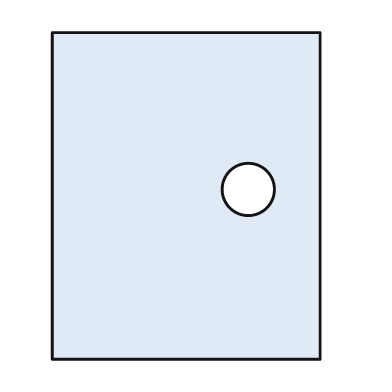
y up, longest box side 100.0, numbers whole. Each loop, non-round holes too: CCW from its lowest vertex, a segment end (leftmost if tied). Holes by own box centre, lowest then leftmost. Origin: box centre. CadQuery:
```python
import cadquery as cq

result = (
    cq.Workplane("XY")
    .moveTo(-41.0, -50.0)
    .lineTo(41.0, -50.0)
    .lineTo(41.0, 50.0)
    .lineTo(-41.0, 50.0)
    .close()
    .moveTo(19.0, 2.0)
    .circle(8.0)
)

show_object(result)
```